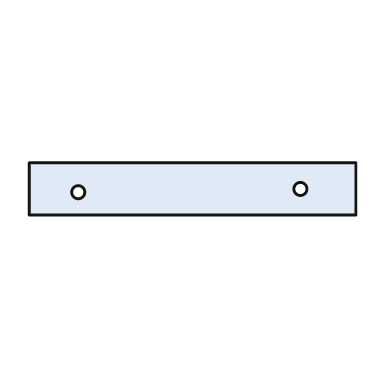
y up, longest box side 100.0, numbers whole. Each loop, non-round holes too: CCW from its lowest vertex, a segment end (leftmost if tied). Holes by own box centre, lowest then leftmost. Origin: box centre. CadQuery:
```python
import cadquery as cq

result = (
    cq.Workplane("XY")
    .moveTo(-50.0, -8.0)
    .lineTo(50.0, -8.0)
    .lineTo(50.0, 8.0)
    .lineTo(-50.0, 8.0)
    .close()
    .moveTo(-35.0, -1.0)
    .circle(2.0)
    .moveTo(33.0, 0.0)
    .circle(2.0)
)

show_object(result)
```